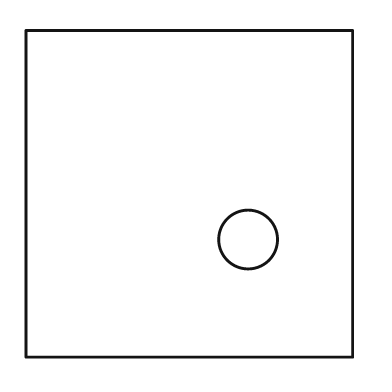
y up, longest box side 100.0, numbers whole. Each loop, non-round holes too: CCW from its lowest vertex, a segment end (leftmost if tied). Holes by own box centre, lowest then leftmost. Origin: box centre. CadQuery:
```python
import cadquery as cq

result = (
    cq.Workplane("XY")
    .moveTo(-50.0, -50.0)
    .lineTo(50.0, -50.0)
    .lineTo(50.0, 50.0)
    .lineTo(-50.0, 50.0)
    .close()
    .moveTo(18.0, -14.0)
    .circle(9.0)
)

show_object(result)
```